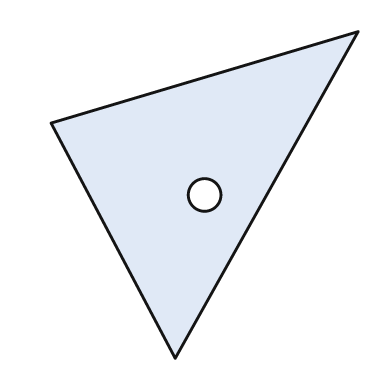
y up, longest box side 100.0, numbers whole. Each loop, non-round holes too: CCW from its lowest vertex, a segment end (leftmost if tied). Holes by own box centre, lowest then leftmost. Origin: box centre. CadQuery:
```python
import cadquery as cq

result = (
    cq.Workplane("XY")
    .moveTo(-9.0, -50.0)
    .lineTo(47.0, 50.0)
    .lineTo(-47.0, 22.0)
    .close()
    .moveTo(0.0, 0.0)
    .circle(5.0)
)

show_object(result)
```